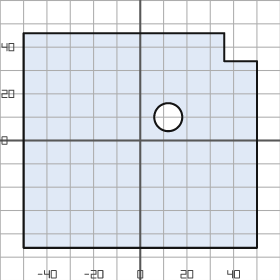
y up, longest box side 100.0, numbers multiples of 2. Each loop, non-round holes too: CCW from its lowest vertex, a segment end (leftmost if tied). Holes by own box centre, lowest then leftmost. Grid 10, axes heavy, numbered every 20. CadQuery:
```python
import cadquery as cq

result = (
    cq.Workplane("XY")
    .moveTo(-50.0, -46.0)
    .lineTo(50.0, -46.0)
    .lineTo(50.0, 34.0)
    .lineTo(36.0, 34.0)
    .lineTo(36.0, 46.0)
    .lineTo(-50.0, 46.0)
    .close()
    .moveTo(12.0, 10.0)
    .circle(6.0)
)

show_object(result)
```